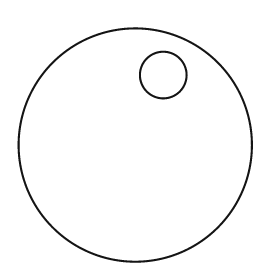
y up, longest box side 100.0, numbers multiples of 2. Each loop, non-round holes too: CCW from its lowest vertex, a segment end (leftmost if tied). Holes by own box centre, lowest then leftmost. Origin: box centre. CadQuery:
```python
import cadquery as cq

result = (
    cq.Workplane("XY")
    .moveTo(0.0, 0.0)
    .circle(50.0)
    .moveTo(12.0, 30.0)
    .circle(10.0)
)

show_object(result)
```